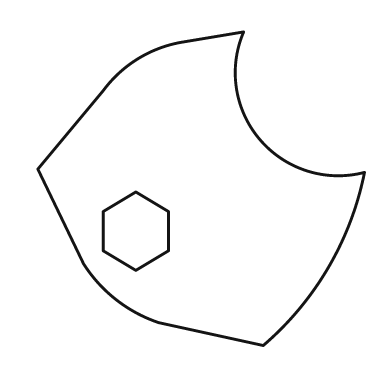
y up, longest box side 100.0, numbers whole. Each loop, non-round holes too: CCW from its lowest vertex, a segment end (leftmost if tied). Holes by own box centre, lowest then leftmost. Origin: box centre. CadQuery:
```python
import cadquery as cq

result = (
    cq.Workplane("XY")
    .moveTo(19.0, -48.0)
    .threePointArc((39.0, -24.0), (50.0, 5.0))
    .threePointArc((18.0, 15.0), (13.0, 48.0))
    .lineTo(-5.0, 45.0)
    .threePointArc((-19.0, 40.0), (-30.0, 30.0))
    .lineTo(-50.0, 6.0)
    .lineTo(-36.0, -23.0)
    .threePointArc((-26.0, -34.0), (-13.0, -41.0))
    .close()
    .moveTo(-20.0, -25.0)
    .lineTo(-10.0, -19.0)
    .lineTo(-10.0, -7.0)
    .lineTo(-20.0, -1.0)
    .lineTo(-30.0, -7.0)
    .lineTo(-30.0, -19.0)
    .close()
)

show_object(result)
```